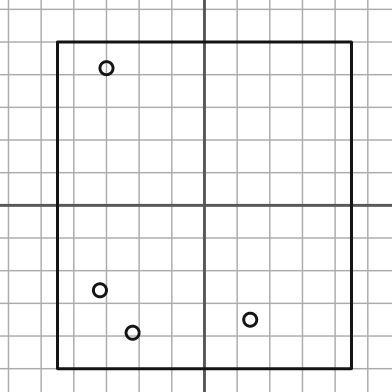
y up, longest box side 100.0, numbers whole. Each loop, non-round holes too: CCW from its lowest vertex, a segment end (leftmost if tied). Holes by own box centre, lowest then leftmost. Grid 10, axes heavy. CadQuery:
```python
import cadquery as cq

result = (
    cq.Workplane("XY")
    .moveTo(-45.0, -50.0)
    .lineTo(45.0, -50.0)
    .lineTo(45.0, 50.0)
    .lineTo(-45.0, 50.0)
    .close()
    .moveTo(-22.0, -39.0)
    .circle(2.0)
    .moveTo(14.0, -35.0)
    .circle(2.0)
    .moveTo(-32.0, -26.0)
    .circle(2.0)
    .moveTo(-30.0, 42.0)
    .circle(2.0)
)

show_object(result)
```